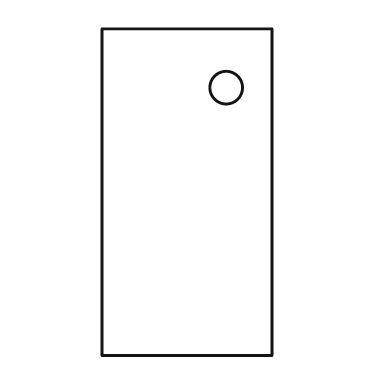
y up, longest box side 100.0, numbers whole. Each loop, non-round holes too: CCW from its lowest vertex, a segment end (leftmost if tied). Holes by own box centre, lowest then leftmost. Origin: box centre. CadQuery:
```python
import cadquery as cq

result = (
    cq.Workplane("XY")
    .moveTo(-26.0, -50.0)
    .lineTo(26.0, -50.0)
    .lineTo(26.0, 50.0)
    .lineTo(-26.0, 50.0)
    .close()
    .moveTo(12.0, 32.0)
    .circle(5.0)
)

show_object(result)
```